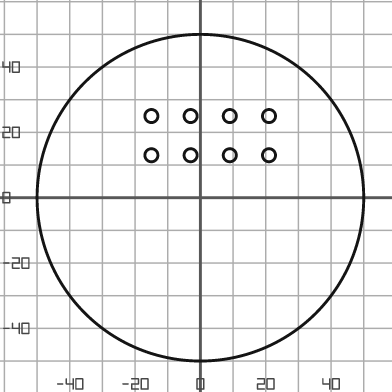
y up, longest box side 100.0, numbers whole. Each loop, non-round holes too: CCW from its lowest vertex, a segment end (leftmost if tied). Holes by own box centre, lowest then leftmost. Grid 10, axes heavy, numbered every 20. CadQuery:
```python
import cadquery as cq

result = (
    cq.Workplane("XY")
    .moveTo(0.0, 0.0)
    .circle(50.0)
    .moveTo(-15.0, 13.0)
    .circle(2.0)
    .moveTo(-3.0, 13.0)
    .circle(2.0)
    .moveTo(9.0, 13.0)
    .circle(2.0)
    .moveTo(21.0, 13.0)
    .circle(2.0)
    .moveTo(-15.0, 25.0)
    .circle(2.0)
    .moveTo(-3.0, 25.0)
    .circle(2.0)
    .moveTo(9.0, 25.0)
    .circle(2.0)
    .moveTo(21.0, 25.0)
    .circle(2.0)
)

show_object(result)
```